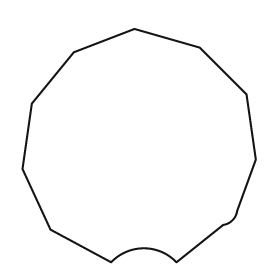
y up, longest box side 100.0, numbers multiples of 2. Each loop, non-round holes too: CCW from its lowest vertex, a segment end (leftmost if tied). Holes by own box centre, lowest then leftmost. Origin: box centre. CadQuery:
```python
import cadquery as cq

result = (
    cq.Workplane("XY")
    .moveTo(-12.0, -50.0)
    .threePointArc((2.0, -44.0), (16.0, -50.0))
    .lineTo(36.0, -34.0)
    .threePointArc((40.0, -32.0), (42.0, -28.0))
    .lineTo(50.0, -6.0)
    .lineTo(46.0, 22.0)
    .lineTo(26.0, 42.0)
    .lineTo(-2.0, 50.0)
    .lineTo(-28.0, 40.0)
    .lineTo(-46.0, 18.0)
    .lineTo(-50.0, -10.0)
    .lineTo(-38.0, -36.0)
    .close()
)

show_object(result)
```